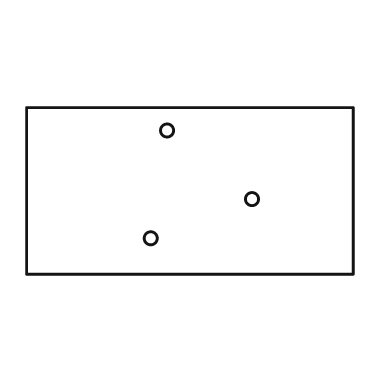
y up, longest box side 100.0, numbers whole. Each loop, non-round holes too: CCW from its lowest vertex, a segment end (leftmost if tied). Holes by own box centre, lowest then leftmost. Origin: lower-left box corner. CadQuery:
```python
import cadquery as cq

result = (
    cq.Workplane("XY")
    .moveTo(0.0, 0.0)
    .lineTo(100.0, 0.0)
    .lineTo(100.0, 51.0)
    .lineTo(0.0, 51.0)
    .close()
    .moveTo(38.0, 11.0)
    .circle(2.0)
    .moveTo(69.0, 23.0)
    .circle(2.0)
    .moveTo(43.0, 44.0)
    .circle(2.0)
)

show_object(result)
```